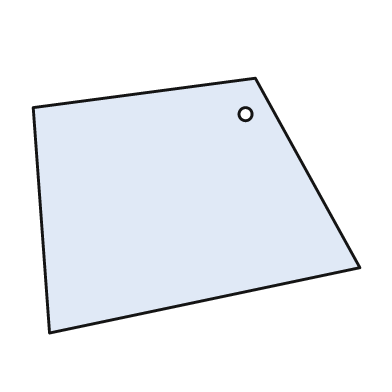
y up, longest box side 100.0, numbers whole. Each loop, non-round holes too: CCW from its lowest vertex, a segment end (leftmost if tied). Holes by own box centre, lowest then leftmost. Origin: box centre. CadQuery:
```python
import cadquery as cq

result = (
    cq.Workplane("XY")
    .moveTo(-45.0, -39.0)
    .lineTo(50.0, -19.0)
    .lineTo(18.0, 39.0)
    .lineTo(-50.0, 30.0)
    .close()
    .moveTo(15.0, 28.0)
    .circle(2.0)
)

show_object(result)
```